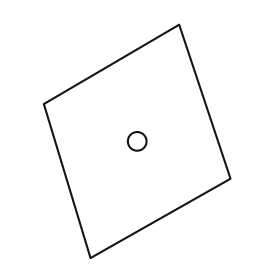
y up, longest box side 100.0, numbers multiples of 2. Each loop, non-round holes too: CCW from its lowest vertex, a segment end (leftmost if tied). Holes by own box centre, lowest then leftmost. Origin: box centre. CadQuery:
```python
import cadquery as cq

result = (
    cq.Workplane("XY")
    .moveTo(-20.0, -50.0)
    .lineTo(40.0, -16.0)
    .lineTo(18.0, 50.0)
    .lineTo(-40.0, 16.0)
    .close()
    .moveTo(0.0, 0.0)
    .circle(4.0)
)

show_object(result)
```